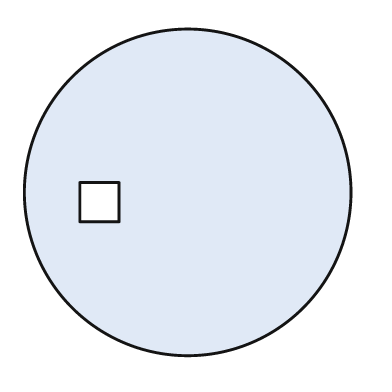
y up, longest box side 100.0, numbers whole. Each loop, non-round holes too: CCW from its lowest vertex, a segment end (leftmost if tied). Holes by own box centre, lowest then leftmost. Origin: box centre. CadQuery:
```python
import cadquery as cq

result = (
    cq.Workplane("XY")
    .moveTo(0.0, 0.0)
    .circle(50.0)
    .moveTo(-33.0, -9.0)
    .lineTo(-21.0, -9.0)
    .lineTo(-21.0, 3.0)
    .lineTo(-33.0, 3.0)
    .close()
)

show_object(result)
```